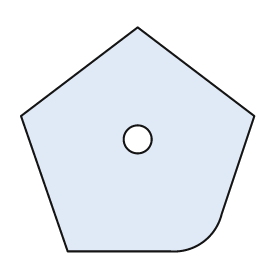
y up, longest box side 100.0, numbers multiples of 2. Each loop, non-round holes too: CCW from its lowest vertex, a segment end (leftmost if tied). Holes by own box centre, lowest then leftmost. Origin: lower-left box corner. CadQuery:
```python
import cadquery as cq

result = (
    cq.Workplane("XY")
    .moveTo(20.0, 0.0)
    .lineTo(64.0, 0.0)
    .threePointArc((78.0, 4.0), (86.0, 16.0))
    .lineTo(100.0, 58.0)
    .lineTo(50.0, 96.0)
    .lineTo(0.0, 58.0)
    .close()
    .moveTo(50.0, 48.0)
    .circle(6.0)
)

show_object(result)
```